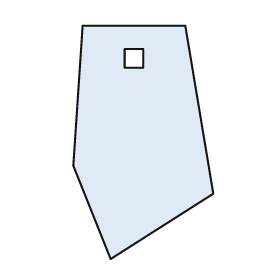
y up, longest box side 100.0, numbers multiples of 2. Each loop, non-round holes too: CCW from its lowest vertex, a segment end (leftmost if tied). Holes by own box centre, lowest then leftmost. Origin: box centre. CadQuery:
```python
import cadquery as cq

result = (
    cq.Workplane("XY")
    .moveTo(-14.0, -50.0)
    .lineTo(30.0, -22.0)
    .lineTo(18.0, 50.0)
    .lineTo(-26.0, 50.0)
    .lineTo(-30.0, -10.0)
    .close()
    .moveTo(-8.0, 32.0)
    .lineTo(0.0, 32.0)
    .lineTo(0.0, 40.0)
    .lineTo(-8.0, 40.0)
    .close()
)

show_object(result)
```